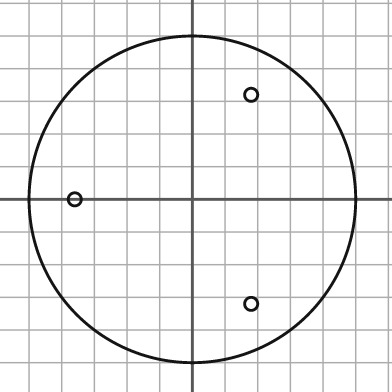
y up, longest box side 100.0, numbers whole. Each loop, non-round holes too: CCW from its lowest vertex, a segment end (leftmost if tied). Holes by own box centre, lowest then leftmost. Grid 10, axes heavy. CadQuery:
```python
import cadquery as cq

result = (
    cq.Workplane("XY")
    .moveTo(0.0, 0.0)
    .circle(50.0)
    .moveTo(18.0, -32.0)
    .circle(2.0)
    .moveTo(-36.0, 0.0)
    .circle(2.0)
    .moveTo(18.0, 32.0)
    .circle(2.0)
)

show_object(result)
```